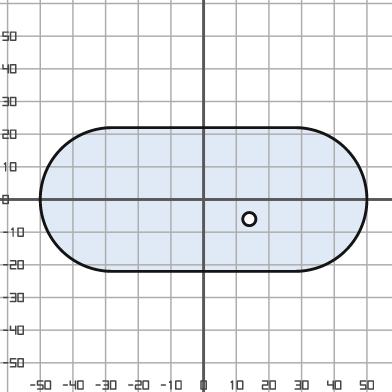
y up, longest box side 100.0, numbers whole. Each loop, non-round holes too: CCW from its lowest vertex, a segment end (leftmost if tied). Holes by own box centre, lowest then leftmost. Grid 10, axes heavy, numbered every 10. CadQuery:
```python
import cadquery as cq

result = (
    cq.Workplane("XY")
    .moveTo(-28.0, -22.0)
    .lineTo(28.0, -22.0)
    .threePointArc((50.0, 0.0), (28.0, 22.0))
    .lineTo(-28.0, 22.0)
    .threePointArc((-50.0, 0.0), (-28.0, -22.0))
    .close()
    .moveTo(14.0, -6.0)
    .circle(2.0)
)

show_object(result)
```